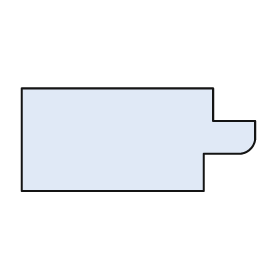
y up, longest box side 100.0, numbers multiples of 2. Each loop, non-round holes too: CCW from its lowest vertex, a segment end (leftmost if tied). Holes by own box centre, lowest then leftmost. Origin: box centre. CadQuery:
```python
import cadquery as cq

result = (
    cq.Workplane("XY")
    .moveTo(-50.0, -22.0)
    .lineTo(28.0, -22.0)
    .lineTo(28.0, -6.0)
    .lineTo(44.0, -6.0)
    .threePointArc((48.0, -4.0), (50.0, 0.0))
    .lineTo(50.0, 8.0)
    .lineTo(32.0, 8.0)
    .lineTo(32.0, 22.0)
    .lineTo(-50.0, 22.0)
    .close()
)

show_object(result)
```